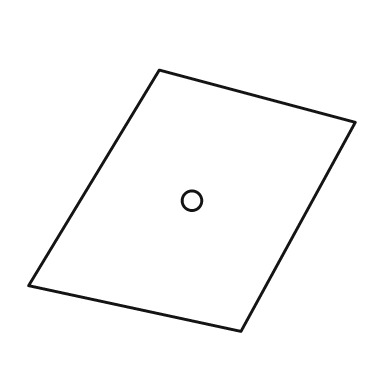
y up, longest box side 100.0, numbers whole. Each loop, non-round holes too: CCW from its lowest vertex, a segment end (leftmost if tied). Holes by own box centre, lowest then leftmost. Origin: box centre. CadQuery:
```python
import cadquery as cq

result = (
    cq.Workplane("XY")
    .moveTo(15.0, -40.0)
    .lineTo(50.0, 24.0)
    .lineTo(-10.0, 40.0)
    .lineTo(-50.0, -26.0)
    .close()
    .moveTo(0.0, 0.0)
    .circle(3.0)
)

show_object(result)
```